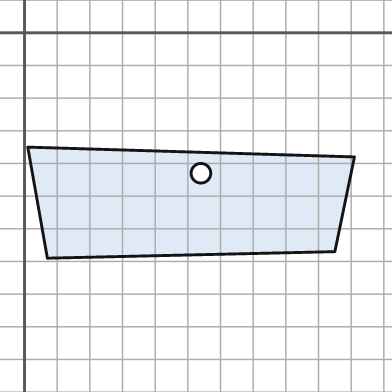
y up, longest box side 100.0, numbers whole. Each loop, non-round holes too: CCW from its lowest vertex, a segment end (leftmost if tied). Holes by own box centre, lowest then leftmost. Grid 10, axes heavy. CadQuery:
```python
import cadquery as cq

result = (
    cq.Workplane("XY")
    .moveTo(7.0, -69.0)
    .lineTo(95.0, -67.0)
    .lineTo(101.0, -38.0)
    .lineTo(1.0, -35.0)
    .close()
    .moveTo(54.0, -43.0)
    .circle(3.0)
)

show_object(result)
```